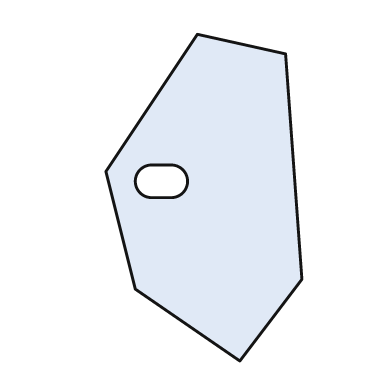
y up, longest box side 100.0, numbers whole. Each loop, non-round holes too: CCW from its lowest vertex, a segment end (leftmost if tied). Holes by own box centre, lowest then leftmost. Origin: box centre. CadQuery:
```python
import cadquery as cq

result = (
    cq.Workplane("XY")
    .moveTo(11.0, -50.0)
    .lineTo(30.0, -25.0)
    .lineTo(25.0, 44.0)
    .lineTo(-2.0, 50.0)
    .lineTo(-30.0, 8.0)
    .lineTo(-21.0, -28.0)
    .close()
    .moveTo(-16.0, 0.0)
    .lineTo(-10.0, 0.0)
    .threePointArc((-5.0, 5.0), (-10.0, 10.0))
    .lineTo(-16.0, 10.0)
    .threePointArc((-21.0, 5.0), (-16.0, 0.0))
    .close()
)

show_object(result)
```